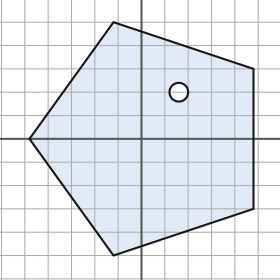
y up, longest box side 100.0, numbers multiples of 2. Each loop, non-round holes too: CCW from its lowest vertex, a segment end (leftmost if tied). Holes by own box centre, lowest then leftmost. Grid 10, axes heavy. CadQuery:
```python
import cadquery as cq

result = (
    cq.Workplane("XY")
    .moveTo(-12.0, -50.0)
    .lineTo(48.0, -30.0)
    .lineTo(48.0, 30.0)
    .lineTo(-12.0, 50.0)
    .lineTo(-48.0, 0.0)
    .close()
    .moveTo(16.0, 20.0)
    .circle(4.0)
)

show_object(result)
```